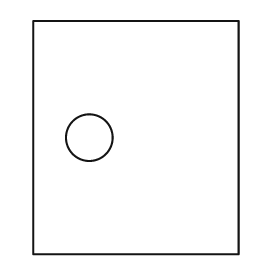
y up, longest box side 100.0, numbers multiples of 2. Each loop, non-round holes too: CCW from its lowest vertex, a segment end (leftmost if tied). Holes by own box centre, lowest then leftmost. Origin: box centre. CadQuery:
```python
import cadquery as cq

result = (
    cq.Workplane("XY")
    .moveTo(-44.0, -50.0)
    .lineTo(44.0, -50.0)
    .lineTo(44.0, 50.0)
    .lineTo(-44.0, 50.0)
    .close()
    .moveTo(-20.0, 0.0)
    .circle(10.0)
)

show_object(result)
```